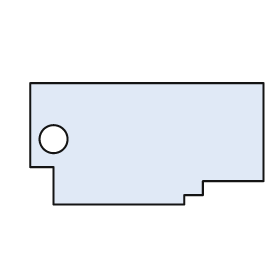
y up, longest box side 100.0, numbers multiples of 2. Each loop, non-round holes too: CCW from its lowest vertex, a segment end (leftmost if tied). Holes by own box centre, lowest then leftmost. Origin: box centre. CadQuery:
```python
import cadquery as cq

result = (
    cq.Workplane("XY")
    .moveTo(-40.0, -26.0)
    .lineTo(16.0, -26.0)
    .lineTo(16.0, -22.0)
    .lineTo(24.0, -22.0)
    .lineTo(24.0, -16.0)
    .lineTo(50.0, -16.0)
    .lineTo(50.0, 26.0)
    .lineTo(-50.0, 26.0)
    .lineTo(-50.0, -10.0)
    .lineTo(-40.0, -10.0)
    .close()
    .moveTo(-40.0, 2.0)
    .circle(6.0)
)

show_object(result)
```